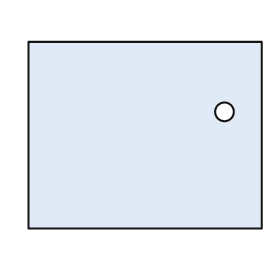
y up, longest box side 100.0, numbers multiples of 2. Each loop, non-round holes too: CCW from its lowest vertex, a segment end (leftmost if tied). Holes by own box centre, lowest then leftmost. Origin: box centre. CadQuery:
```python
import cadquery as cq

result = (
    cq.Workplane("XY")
    .moveTo(-50.0, -40.0)
    .lineTo(50.0, -40.0)
    .lineTo(50.0, 40.0)
    .lineTo(-50.0, 40.0)
    .close()
    .moveTo(34.0, 10.0)
    .circle(4.0)
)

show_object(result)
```